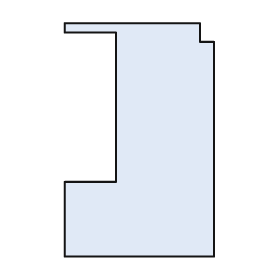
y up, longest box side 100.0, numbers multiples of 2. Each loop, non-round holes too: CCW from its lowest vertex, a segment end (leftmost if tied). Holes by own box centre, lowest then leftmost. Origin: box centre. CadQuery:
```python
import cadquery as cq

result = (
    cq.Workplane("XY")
    .moveTo(-32.0, -50.0)
    .lineTo(32.0, -50.0)
    .lineTo(32.0, 42.0)
    .lineTo(26.0, 42.0)
    .lineTo(26.0, 50.0)
    .lineTo(-32.0, 50.0)
    .lineTo(-32.0, 46.0)
    .lineTo(-10.0, 46.0)
    .lineTo(-10.0, -18.0)
    .lineTo(-32.0, -18.0)
    .close()
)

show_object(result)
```